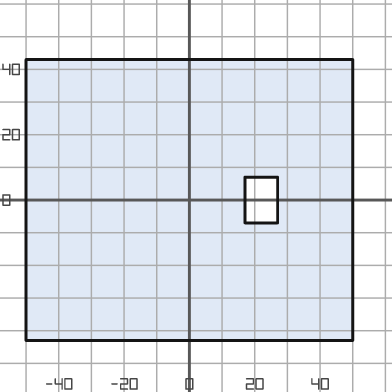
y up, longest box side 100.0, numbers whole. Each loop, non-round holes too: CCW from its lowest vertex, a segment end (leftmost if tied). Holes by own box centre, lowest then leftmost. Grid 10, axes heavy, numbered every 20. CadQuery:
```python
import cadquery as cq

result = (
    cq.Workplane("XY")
    .moveTo(-50.0, -43.0)
    .lineTo(50.0, -43.0)
    .lineTo(50.0, 43.0)
    .lineTo(-50.0, 43.0)
    .close()
    .moveTo(17.0, -7.0)
    .lineTo(27.0, -7.0)
    .lineTo(27.0, 7.0)
    .lineTo(17.0, 7.0)
    .close()
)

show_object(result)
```